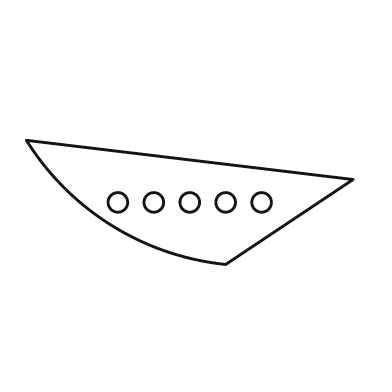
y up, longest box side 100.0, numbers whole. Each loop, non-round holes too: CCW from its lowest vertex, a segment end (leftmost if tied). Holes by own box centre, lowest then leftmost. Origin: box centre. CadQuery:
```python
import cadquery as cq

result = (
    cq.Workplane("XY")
    .moveTo(11.0, -19.0)
    .lineTo(50.0, 7.0)
    .lineTo(-50.0, 19.0)
    .threePointArc((-24.0, -7.0), (11.0, -19.0))
    .close()
    .moveTo(-22.0, 0.0)
    .circle(3.0)
    .moveTo(-11.0, 0.0)
    .circle(3.0)
    .moveTo(0.0, 0.0)
    .circle(3.0)
    .moveTo(11.0, 0.0)
    .circle(3.0)
    .moveTo(22.0, 0.0)
    .circle(3.0)
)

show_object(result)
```